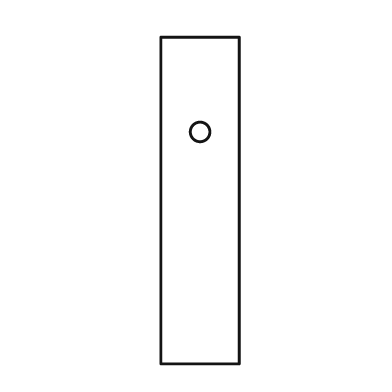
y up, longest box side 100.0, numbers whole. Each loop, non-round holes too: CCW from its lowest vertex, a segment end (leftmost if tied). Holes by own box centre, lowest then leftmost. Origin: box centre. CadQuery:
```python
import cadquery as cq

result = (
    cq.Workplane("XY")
    .moveTo(-12.0, -50.0)
    .lineTo(12.0, -50.0)
    .lineTo(12.0, 50.0)
    .lineTo(-12.0, 50.0)
    .close()
    .moveTo(0.0, 21.0)
    .circle(3.0)
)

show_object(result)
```